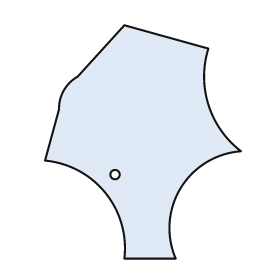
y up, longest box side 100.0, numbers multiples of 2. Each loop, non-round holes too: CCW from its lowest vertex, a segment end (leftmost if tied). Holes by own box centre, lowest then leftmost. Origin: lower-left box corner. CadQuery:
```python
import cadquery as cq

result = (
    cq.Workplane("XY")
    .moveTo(34.0, 0.0)
    .lineTo(56.0, 0.0)
    .threePointArc((58.0, 30.0), (84.0, 46.0))
    .threePointArc((70.0, 66.0), (70.0, 90.0))
    .lineTo(34.0, 100.0)
    .lineTo(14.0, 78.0)
    .threePointArc((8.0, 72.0), (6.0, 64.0))
    .lineTo(0.0, 42.0)
    .threePointArc((26.0, 28.0), (34.0, 0.0))
    .close()
    .moveTo(30.0, 36.0)
    .circle(2.0)
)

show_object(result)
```